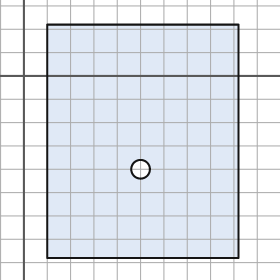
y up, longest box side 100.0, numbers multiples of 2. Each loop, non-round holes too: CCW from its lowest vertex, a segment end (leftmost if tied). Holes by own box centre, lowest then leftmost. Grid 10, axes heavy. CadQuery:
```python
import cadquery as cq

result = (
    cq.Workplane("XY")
    .moveTo(10.0, -78.0)
    .lineTo(92.0, -78.0)
    .lineTo(92.0, 22.0)
    .lineTo(10.0, 22.0)
    .close()
    .moveTo(50.0, -40.0)
    .circle(4.0)
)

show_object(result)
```